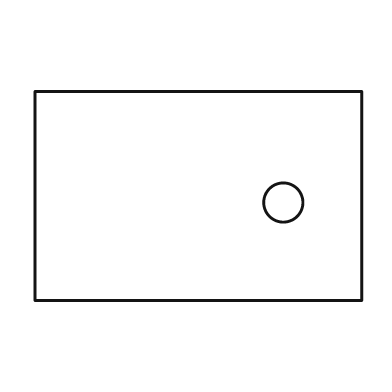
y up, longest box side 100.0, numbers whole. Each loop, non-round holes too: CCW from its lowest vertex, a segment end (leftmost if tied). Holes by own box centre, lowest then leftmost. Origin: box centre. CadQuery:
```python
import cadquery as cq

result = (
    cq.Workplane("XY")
    .moveTo(-50.0, -32.0)
    .lineTo(50.0, -32.0)
    .lineTo(50.0, 32.0)
    .lineTo(-50.0, 32.0)
    .close()
    .moveTo(26.0, -2.0)
    .circle(6.0)
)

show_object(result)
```